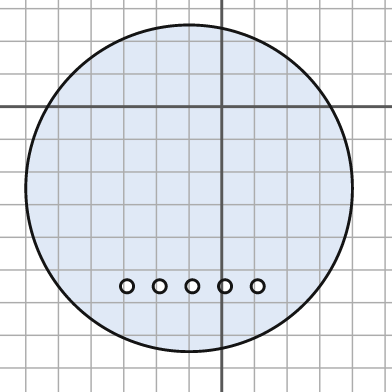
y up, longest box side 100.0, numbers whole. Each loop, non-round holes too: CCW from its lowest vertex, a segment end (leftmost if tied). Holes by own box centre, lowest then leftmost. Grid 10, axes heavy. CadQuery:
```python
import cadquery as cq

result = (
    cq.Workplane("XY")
    .moveTo(-10.0, -25.0)
    .circle(50.0)
    .moveTo(-29.0, -55.0)
    .circle(2.0)
    .moveTo(-19.0, -55.0)
    .circle(2.0)
    .moveTo(-9.0, -55.0)
    .circle(2.0)
    .moveTo(1.0, -55.0)
    .circle(2.0)
    .moveTo(11.0, -55.0)
    .circle(2.0)
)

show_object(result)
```